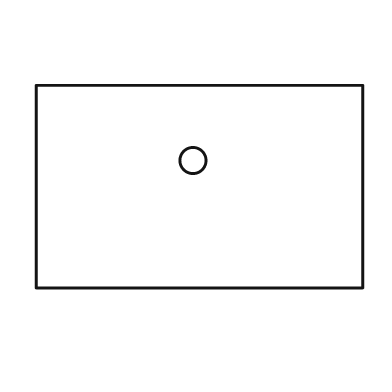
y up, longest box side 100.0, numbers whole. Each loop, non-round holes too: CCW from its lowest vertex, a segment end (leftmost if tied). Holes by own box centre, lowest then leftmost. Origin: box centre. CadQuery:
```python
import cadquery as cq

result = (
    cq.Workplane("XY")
    .moveTo(-50.0, -31.0)
    .lineTo(50.0, -31.0)
    .lineTo(50.0, 31.0)
    .lineTo(-50.0, 31.0)
    .close()
    .moveTo(-2.0, 8.0)
    .circle(4.0)
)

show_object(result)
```